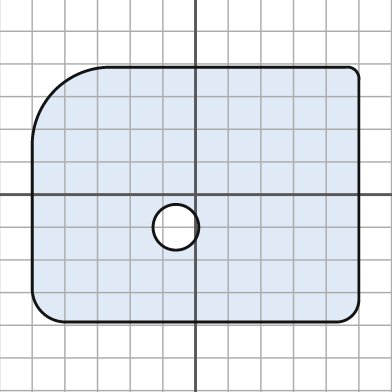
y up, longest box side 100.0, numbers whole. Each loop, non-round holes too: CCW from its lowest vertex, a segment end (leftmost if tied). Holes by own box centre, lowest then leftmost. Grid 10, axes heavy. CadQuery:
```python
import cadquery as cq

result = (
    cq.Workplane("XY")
    .moveTo(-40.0, -39.0)
    .lineTo(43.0, -39.0)
    .threePointArc((48.0, -37.0), (50.0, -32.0))
    .lineTo(50.0, 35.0)
    .threePointArc((49.0, 38.0), (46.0, 39.0))
    .lineTo(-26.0, 39.0)
    .threePointArc((-43.0, 32.0), (-50.0, 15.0))
    .lineTo(-50.0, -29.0)
    .threePointArc((-47.0, -36.0), (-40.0, -39.0))
    .close()
    .moveTo(-6.0, -10.0)
    .circle(7.0)
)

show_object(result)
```